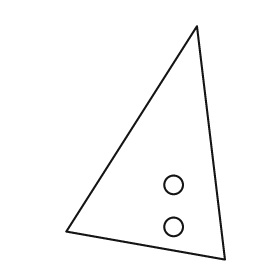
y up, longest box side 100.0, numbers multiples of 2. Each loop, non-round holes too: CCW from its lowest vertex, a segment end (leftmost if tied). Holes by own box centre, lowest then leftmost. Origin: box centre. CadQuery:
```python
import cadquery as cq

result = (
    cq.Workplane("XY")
    .moveTo(34.0, -50.0)
    .lineTo(22.0, 50.0)
    .lineTo(-34.0, -38.0)
    .close()
    .moveTo(12.0, -36.0)
    .circle(4.0)
    .moveTo(12.0, -18.0)
    .circle(4.0)
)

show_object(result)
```